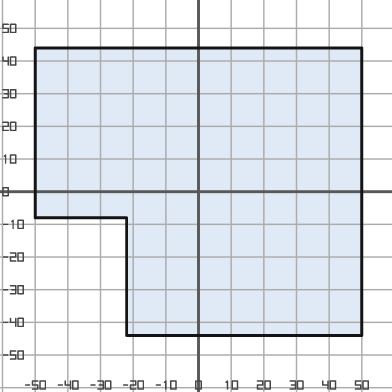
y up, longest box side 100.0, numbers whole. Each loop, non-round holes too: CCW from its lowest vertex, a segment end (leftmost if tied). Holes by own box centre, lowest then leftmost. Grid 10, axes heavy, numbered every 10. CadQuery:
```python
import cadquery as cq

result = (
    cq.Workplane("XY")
    .moveTo(-22.0, -44.0)
    .lineTo(50.0, -44.0)
    .lineTo(50.0, 44.0)
    .lineTo(-50.0, 44.0)
    .lineTo(-50.0, -8.0)
    .lineTo(-22.0, -8.0)
    .close()
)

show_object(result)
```